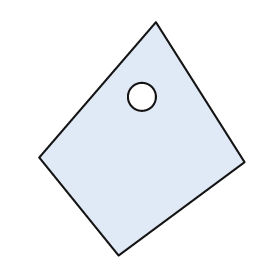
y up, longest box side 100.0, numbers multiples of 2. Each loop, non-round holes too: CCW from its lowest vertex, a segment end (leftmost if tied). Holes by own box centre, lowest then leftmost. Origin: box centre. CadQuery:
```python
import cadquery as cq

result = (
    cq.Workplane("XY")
    .moveTo(-10.0, -50.0)
    .lineTo(44.0, -10.0)
    .lineTo(6.0, 50.0)
    .lineTo(-44.0, -8.0)
    .close()
    .moveTo(0.0, 18.0)
    .circle(6.0)
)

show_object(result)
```